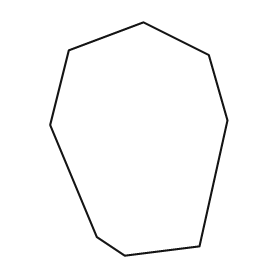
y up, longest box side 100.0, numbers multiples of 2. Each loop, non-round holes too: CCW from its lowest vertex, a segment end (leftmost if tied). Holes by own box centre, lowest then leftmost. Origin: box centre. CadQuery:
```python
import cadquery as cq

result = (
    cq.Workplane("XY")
    .moveTo(-6.0, -50.0)
    .lineTo(26.0, -46.0)
    .lineTo(38.0, 8.0)
    .lineTo(30.0, 36.0)
    .lineTo(2.0, 50.0)
    .lineTo(-30.0, 38.0)
    .lineTo(-38.0, 6.0)
    .lineTo(-18.0, -42.0)
    .close()
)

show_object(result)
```